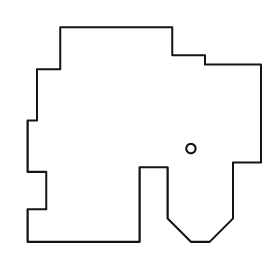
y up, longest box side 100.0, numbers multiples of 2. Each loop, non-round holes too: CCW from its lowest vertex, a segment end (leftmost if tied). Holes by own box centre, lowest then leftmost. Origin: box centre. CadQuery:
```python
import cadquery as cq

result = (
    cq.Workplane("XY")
    .moveTo(-50.0, -46.0)
    .lineTo(-2.0, -46.0)
    .lineTo(-2.0, -14.0)
    .lineTo(10.0, -14.0)
    .lineTo(10.0, -36.0)
    .lineTo(20.0, -46.0)
    .lineTo(28.0, -46.0)
    .lineTo(38.0, -36.0)
    .lineTo(38.0, -12.0)
    .lineTo(50.0, -12.0)
    .lineTo(50.0, 30.0)
    .lineTo(26.0, 30.0)
    .lineTo(26.0, 34.0)
    .lineTo(12.0, 34.0)
    .lineTo(12.0, 46.0)
    .lineTo(-36.0, 46.0)
    .lineTo(-36.0, 28.0)
    .lineTo(-46.0, 28.0)
    .lineTo(-46.0, 6.0)
    .lineTo(-50.0, 6.0)
    .lineTo(-50.0, -16.0)
    .lineTo(-42.0, -16.0)
    .lineTo(-42.0, -32.0)
    .lineTo(-50.0, -32.0)
    .close()
    .moveTo(20.0, -6.0)
    .circle(2.0)
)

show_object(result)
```